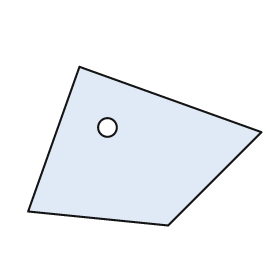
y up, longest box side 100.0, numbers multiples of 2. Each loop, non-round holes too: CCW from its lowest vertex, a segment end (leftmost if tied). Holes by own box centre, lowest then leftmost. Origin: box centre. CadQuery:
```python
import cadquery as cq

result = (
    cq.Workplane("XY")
    .moveTo(10.0, -34.0)
    .lineTo(50.0, 6.0)
    .lineTo(-28.0, 34.0)
    .lineTo(-50.0, -28.0)
    .close()
    .moveTo(-16.0, 8.0)
    .circle(4.0)
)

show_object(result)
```